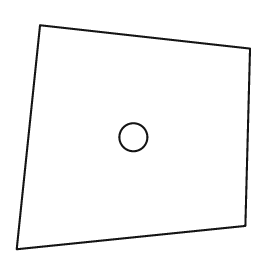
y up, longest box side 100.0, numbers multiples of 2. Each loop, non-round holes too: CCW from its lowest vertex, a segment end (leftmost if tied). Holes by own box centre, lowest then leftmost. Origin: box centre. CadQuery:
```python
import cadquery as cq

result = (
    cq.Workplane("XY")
    .moveTo(-50.0, -48.0)
    .lineTo(48.0, -38.0)
    .lineTo(50.0, 38.0)
    .lineTo(-40.0, 48.0)
    .close()
    .moveTo(0.0, 0.0)
    .circle(6.0)
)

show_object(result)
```